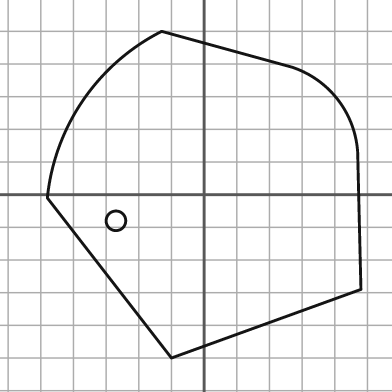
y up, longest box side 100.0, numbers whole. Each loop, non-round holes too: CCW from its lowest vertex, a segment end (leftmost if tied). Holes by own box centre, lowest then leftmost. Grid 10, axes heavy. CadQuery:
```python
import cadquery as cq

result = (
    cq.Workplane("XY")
    .moveTo(-10.0, -50.0)
    .lineTo(48.0, -29.0)
    .lineTo(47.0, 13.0)
    .threePointArc((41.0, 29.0), (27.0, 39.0))
    .lineTo(-13.0, 50.0)
    .threePointArc((-37.0, 29.0), (-48.0, -1.0))
    .close()
    .moveTo(-27.0, -8.0)
    .circle(3.0)
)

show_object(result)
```